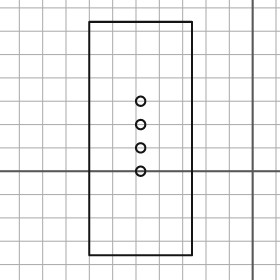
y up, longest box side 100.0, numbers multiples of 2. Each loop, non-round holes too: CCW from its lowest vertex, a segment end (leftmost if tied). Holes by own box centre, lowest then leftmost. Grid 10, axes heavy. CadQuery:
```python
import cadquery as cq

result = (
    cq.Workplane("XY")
    .moveTo(-70.0, -36.0)
    .lineTo(-26.0, -36.0)
    .lineTo(-26.0, 64.0)
    .lineTo(-70.0, 64.0)
    .close()
    .moveTo(-48.0, 0.0)
    .circle(2.0)
    .moveTo(-48.0, 10.0)
    .circle(2.0)
    .moveTo(-48.0, 20.0)
    .circle(2.0)
    .moveTo(-48.0, 30.0)
    .circle(2.0)
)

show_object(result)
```